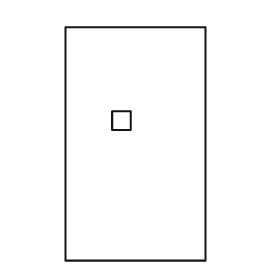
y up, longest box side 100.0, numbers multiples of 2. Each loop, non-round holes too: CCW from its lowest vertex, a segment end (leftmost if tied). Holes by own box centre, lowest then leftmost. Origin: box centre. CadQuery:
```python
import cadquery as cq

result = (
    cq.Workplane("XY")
    .moveTo(-30.0, -50.0)
    .lineTo(30.0, -50.0)
    .lineTo(30.0, 50.0)
    .lineTo(-30.0, 50.0)
    .close()
    .moveTo(-10.0, 6.0)
    .lineTo(-2.0, 6.0)
    .lineTo(-2.0, 14.0)
    .lineTo(-10.0, 14.0)
    .close()
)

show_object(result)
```